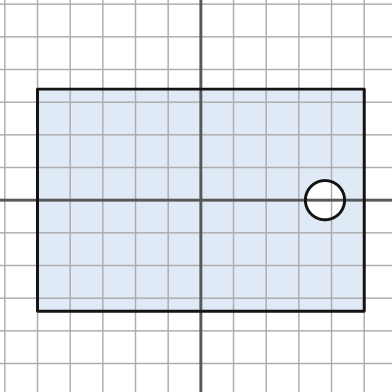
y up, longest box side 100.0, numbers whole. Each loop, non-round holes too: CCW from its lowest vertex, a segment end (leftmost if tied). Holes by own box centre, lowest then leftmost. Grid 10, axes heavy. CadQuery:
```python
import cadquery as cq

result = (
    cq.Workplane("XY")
    .moveTo(-50.0, -34.0)
    .lineTo(50.0, -34.0)
    .lineTo(50.0, 34.0)
    .lineTo(-50.0, 34.0)
    .close()
    .moveTo(38.0, 0.0)
    .circle(6.0)
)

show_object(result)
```